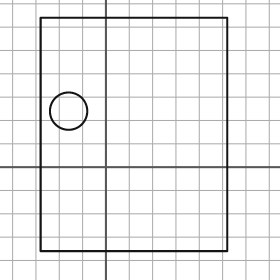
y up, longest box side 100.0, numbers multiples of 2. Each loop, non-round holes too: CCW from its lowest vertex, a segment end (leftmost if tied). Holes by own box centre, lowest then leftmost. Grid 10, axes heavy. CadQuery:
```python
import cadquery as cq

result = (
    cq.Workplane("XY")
    .moveTo(-28.0, -36.0)
    .lineTo(52.0, -36.0)
    .lineTo(52.0, 64.0)
    .lineTo(-28.0, 64.0)
    .close()
    .moveTo(-16.0, 24.0)
    .circle(8.0)
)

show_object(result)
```